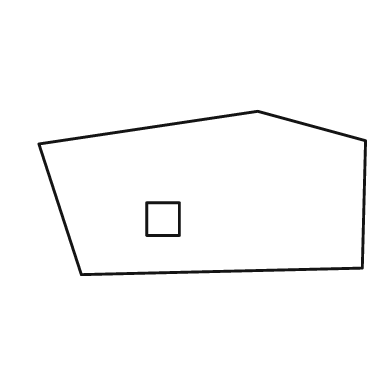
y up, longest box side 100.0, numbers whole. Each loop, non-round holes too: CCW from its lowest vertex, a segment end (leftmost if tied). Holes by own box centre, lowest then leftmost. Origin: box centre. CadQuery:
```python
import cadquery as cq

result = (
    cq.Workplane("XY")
    .moveTo(-37.0, -25.0)
    .lineTo(49.0, -23.0)
    .lineTo(50.0, 16.0)
    .lineTo(17.0, 25.0)
    .lineTo(-50.0, 15.0)
    .close()
    .moveTo(-17.0, -13.0)
    .lineTo(-7.0, -13.0)
    .lineTo(-7.0, -3.0)
    .lineTo(-17.0, -3.0)
    .close()
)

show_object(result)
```